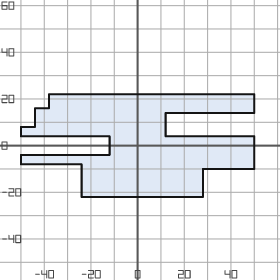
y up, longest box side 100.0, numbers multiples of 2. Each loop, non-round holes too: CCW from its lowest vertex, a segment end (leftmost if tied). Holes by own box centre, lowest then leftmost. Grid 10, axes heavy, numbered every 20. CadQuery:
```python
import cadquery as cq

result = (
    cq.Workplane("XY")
    .moveTo(-24.0, -22.0)
    .lineTo(28.0, -22.0)
    .lineTo(28.0, -10.0)
    .lineTo(50.0, -10.0)
    .lineTo(50.0, 4.0)
    .lineTo(12.0, 4.0)
    .lineTo(12.0, 14.0)
    .lineTo(50.0, 14.0)
    .lineTo(50.0, 22.0)
    .lineTo(-38.0, 22.0)
    .lineTo(-38.0, 16.0)
    .lineTo(-44.0, 16.0)
    .lineTo(-44.0, 8.0)
    .lineTo(-50.0, 8.0)
    .lineTo(-50.0, 4.0)
    .lineTo(-12.0, 4.0)
    .lineTo(-12.0, -4.0)
    .lineTo(-50.0, -4.0)
    .lineTo(-50.0, -8.0)
    .lineTo(-24.0, -8.0)
    .close()
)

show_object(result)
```